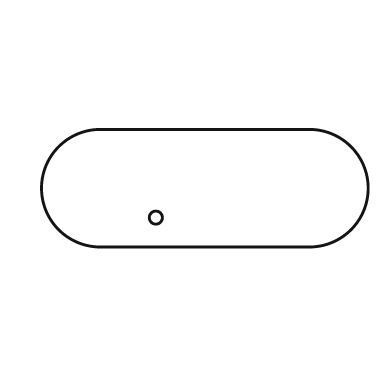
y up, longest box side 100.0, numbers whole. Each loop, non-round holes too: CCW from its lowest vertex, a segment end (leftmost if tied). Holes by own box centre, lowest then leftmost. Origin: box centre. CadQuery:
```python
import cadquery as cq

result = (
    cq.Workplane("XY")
    .moveTo(-32.0, -18.0)
    .lineTo(32.0, -18.0)
    .threePointArc((50.0, 0.0), (32.0, 18.0))
    .lineTo(-32.0, 18.0)
    .threePointArc((-50.0, 0.0), (-32.0, -18.0))
    .close()
    .moveTo(-15.0, -9.0)
    .circle(2.0)
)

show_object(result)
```